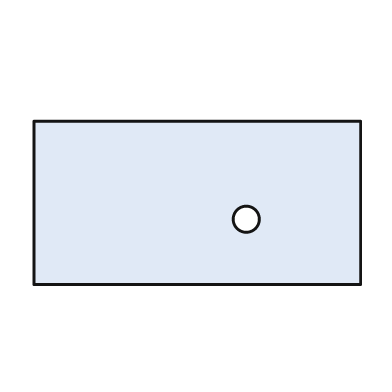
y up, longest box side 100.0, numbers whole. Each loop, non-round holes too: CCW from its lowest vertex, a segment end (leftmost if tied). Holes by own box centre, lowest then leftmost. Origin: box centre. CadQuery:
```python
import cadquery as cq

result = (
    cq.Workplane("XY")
    .moveTo(-50.0, -25.0)
    .lineTo(50.0, -25.0)
    .lineTo(50.0, 25.0)
    .lineTo(-50.0, 25.0)
    .close()
    .moveTo(15.0, -5.0)
    .circle(4.0)
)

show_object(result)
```